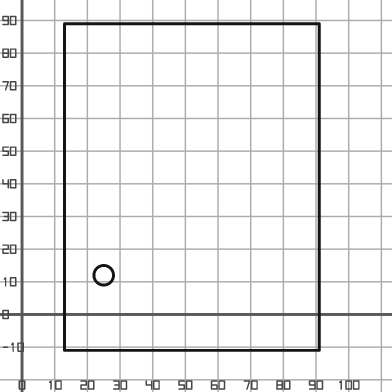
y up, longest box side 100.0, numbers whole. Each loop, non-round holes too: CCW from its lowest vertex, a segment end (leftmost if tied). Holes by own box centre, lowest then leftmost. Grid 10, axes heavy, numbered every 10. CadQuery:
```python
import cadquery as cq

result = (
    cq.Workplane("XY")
    .moveTo(13.0, -11.0)
    .lineTo(91.0, -11.0)
    .lineTo(91.0, 89.0)
    .lineTo(13.0, 89.0)
    .close()
    .moveTo(25.0, 12.0)
    .circle(3.0)
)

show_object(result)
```